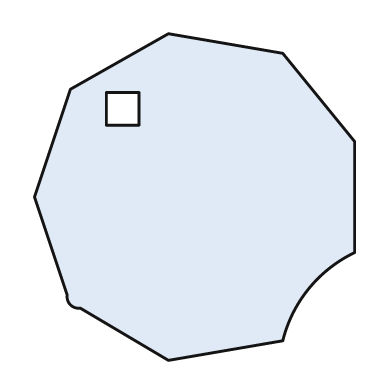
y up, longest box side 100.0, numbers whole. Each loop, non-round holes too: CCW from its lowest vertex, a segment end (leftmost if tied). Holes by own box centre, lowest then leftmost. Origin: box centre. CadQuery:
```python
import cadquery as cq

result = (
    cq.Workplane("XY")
    .moveTo(-8.0, -50.0)
    .lineTo(27.0, -44.0)
    .threePointArc((35.0, -28.0), (49.0, -17.0))
    .lineTo(49.0, 17.0)
    .lineTo(27.0, 44.0)
    .lineTo(-8.0, 50.0)
    .lineTo(-38.0, 33.0)
    .lineTo(-49.0, 0.0)
    .lineTo(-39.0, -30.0)
    .threePointArc((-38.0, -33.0), (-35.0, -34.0))
    .close()
    .moveTo(-27.0, 22.0)
    .lineTo(-17.0, 22.0)
    .lineTo(-17.0, 32.0)
    .lineTo(-27.0, 32.0)
    .close()
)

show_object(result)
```